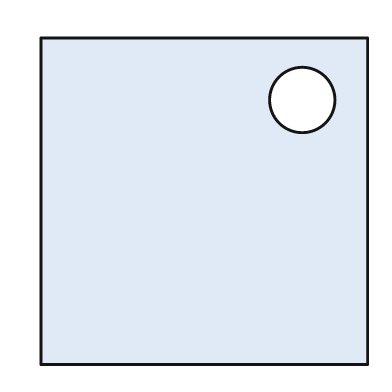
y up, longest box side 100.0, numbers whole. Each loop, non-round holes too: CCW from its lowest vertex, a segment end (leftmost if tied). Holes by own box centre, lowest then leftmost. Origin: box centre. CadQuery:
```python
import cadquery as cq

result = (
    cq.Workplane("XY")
    .moveTo(-50.0, -50.0)
    .lineTo(50.0, -50.0)
    .lineTo(50.0, 50.0)
    .lineTo(-50.0, 50.0)
    .close()
    .moveTo(30.0, 31.0)
    .circle(10.0)
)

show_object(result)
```